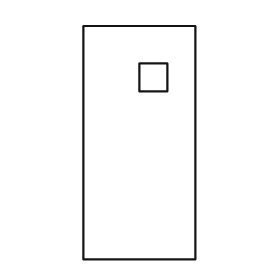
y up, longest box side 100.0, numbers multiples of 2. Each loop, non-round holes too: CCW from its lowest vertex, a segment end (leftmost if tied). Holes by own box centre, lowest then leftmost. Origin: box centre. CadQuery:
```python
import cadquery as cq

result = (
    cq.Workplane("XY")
    .moveTo(-24.0, -50.0)
    .lineTo(24.0, -50.0)
    .lineTo(24.0, 50.0)
    .lineTo(-24.0, 50.0)
    .close()
    .moveTo(0.0, 22.0)
    .lineTo(12.0, 22.0)
    .lineTo(12.0, 34.0)
    .lineTo(0.0, 34.0)
    .close()
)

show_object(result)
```